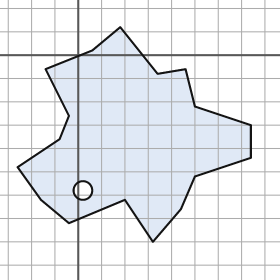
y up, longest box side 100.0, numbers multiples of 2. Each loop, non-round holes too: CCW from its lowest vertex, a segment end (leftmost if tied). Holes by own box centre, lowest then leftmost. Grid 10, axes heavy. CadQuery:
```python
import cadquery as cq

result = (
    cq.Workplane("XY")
    .moveTo(32.0, -80.0)
    .lineTo(44.0, -66.0)
    .lineTo(50.0, -52.0)
    .lineTo(74.0, -44.0)
    .lineTo(74.0, -30.0)
    .lineTo(50.0, -22.0)
    .lineTo(46.0, -6.0)
    .lineTo(34.0, -8.0)
    .lineTo(18.0, 12.0)
    .lineTo(6.0, 2.0)
    .lineTo(-14.0, -6.0)
    .lineTo(-4.0, -26.0)
    .lineTo(-8.0, -36.0)
    .lineTo(-26.0, -48.0)
    .lineTo(-16.0, -62.0)
    .lineTo(-4.0, -72.0)
    .lineTo(20.0, -62.0)
    .close()
    .moveTo(2.0, -58.0)
    .circle(4.0)
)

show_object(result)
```